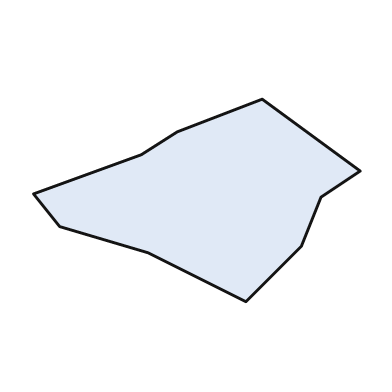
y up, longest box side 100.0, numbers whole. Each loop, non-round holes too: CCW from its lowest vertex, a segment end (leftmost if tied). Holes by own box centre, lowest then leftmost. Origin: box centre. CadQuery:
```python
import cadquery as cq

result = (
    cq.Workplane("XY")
    .moveTo(15.0, -31.0)
    .lineTo(32.0, -14.0)
    .lineTo(38.0, 1.0)
    .lineTo(50.0, 9.0)
    .lineTo(20.0, 31.0)
    .lineTo(-6.0, 21.0)
    .lineTo(-17.0, 14.0)
    .lineTo(-50.0, 2.0)
    .lineTo(-42.0, -8.0)
    .lineTo(-15.0, -16.0)
    .close()
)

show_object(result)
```